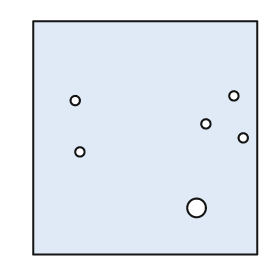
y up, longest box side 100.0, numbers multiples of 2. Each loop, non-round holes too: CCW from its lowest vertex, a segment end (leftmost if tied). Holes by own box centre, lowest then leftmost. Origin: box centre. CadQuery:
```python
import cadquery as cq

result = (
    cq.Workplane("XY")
    .moveTo(-48.0, -50.0)
    .lineTo(48.0, -50.0)
    .lineTo(48.0, 50.0)
    .lineTo(-48.0, 50.0)
    .close()
    .moveTo(22.0, -30.0)
    .circle(4.0)
    .moveTo(-28.0, -6.0)
    .circle(2.0)
    .moveTo(42.0, 0.0)
    .circle(2.0)
    .moveTo(26.0, 6.0)
    .circle(2.0)
    .moveTo(-30.0, 16.0)
    .circle(2.0)
    .moveTo(38.0, 18.0)
    .circle(2.0)
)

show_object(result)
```